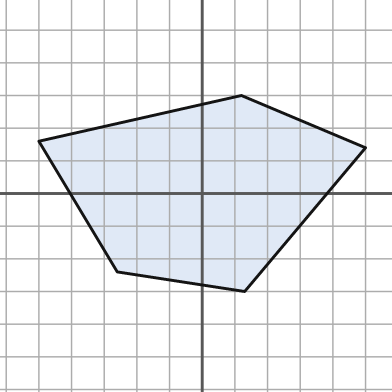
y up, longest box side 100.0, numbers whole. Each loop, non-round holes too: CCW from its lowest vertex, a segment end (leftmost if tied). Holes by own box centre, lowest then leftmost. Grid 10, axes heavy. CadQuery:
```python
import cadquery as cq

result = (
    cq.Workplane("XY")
    .moveTo(13.0, -30.0)
    .lineTo(50.0, 14.0)
    .lineTo(12.0, 30.0)
    .lineTo(-50.0, 16.0)
    .lineTo(-26.0, -24.0)
    .close()
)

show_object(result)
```